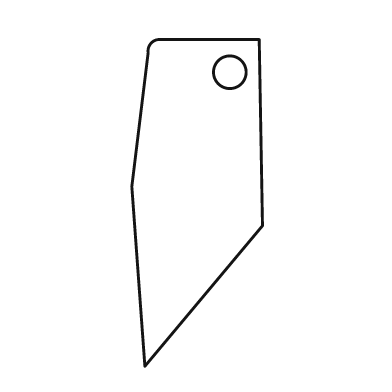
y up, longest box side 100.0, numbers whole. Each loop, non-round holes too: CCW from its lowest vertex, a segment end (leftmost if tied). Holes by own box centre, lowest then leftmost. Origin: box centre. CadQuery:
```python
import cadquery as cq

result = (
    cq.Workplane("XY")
    .moveTo(-16.0, -50.0)
    .lineTo(20.0, -7.0)
    .lineTo(19.0, 50.0)
    .lineTo(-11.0, 50.0)
    .threePointArc((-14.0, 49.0), (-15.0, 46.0))
    .lineTo(-20.0, 5.0)
    .close()
    .moveTo(10.0, 40.0)
    .circle(5.0)
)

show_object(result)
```